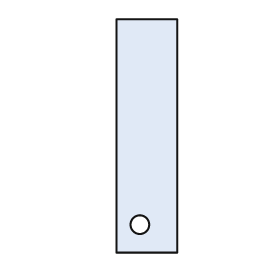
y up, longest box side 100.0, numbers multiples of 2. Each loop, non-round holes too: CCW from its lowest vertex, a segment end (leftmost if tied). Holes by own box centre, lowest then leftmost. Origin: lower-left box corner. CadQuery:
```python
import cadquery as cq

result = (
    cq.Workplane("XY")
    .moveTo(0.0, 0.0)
    .lineTo(26.0, 0.0)
    .lineTo(26.0, 100.0)
    .lineTo(0.0, 100.0)
    .close()
    .moveTo(10.0, 12.0)
    .circle(4.0)
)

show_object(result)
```